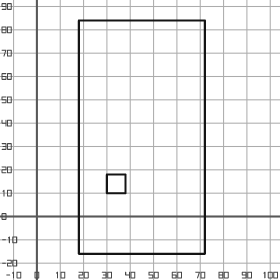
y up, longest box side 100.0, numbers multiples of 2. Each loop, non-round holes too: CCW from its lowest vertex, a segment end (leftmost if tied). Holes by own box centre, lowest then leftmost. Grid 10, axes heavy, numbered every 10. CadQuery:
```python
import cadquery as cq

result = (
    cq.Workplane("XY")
    .moveTo(18.0, -16.0)
    .lineTo(72.0, -16.0)
    .lineTo(72.0, 84.0)
    .lineTo(18.0, 84.0)
    .close()
    .moveTo(30.0, 10.0)
    .lineTo(38.0, 10.0)
    .lineTo(38.0, 18.0)
    .lineTo(30.0, 18.0)
    .close()
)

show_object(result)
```